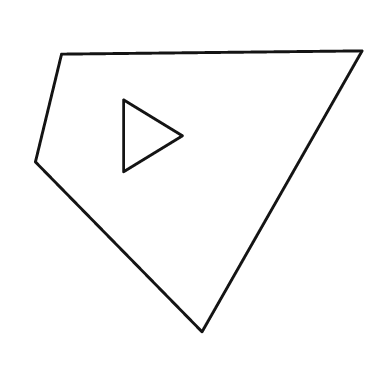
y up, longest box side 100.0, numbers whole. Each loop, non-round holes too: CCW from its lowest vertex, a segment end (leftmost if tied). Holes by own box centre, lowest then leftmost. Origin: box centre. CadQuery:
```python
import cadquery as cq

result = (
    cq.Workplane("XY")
    .moveTo(1.0, -43.0)
    .lineTo(50.0, 43.0)
    .lineTo(-42.0, 42.0)
    .lineTo(-50.0, 9.0)
    .close()
    .moveTo(-23.0, 6.0)
    .lineTo(-5.0, 17.0)
    .lineTo(-23.0, 28.0)
    .close()
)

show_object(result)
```